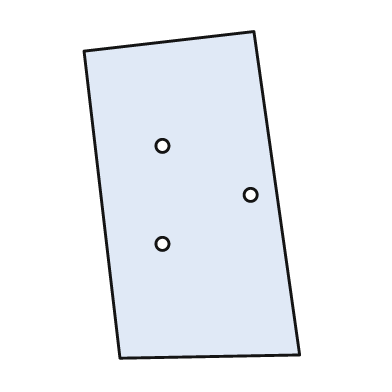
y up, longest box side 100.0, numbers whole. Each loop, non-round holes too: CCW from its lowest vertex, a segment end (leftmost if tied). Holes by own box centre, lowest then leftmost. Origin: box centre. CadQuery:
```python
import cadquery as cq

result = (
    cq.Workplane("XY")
    .moveTo(-22.0, -50.0)
    .lineTo(33.0, -49.0)
    .lineTo(19.0, 50.0)
    .lineTo(-33.0, 44.0)
    .close()
    .moveTo(-9.0, -15.0)
    .circle(2.0)
    .moveTo(18.0, 0.0)
    .circle(2.0)
    .moveTo(-9.0, 15.0)
    .circle(2.0)
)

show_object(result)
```